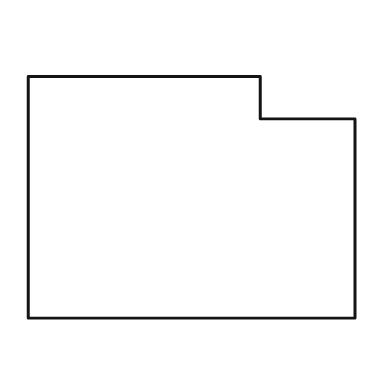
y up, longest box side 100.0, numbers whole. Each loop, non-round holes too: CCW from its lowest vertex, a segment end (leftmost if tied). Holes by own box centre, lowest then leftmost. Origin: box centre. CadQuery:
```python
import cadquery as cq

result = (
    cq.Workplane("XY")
    .moveTo(-50.0, -37.0)
    .lineTo(50.0, -37.0)
    .lineTo(50.0, 24.0)
    .lineTo(21.0, 24.0)
    .lineTo(21.0, 37.0)
    .lineTo(-50.0, 37.0)
    .close()
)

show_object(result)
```